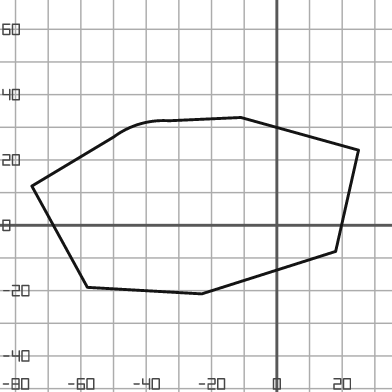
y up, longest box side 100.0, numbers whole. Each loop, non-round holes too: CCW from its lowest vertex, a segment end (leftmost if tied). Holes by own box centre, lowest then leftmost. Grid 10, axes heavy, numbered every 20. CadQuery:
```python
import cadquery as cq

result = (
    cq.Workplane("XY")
    .moveTo(-23.0, -21.0)
    .lineTo(18.0, -8.0)
    .lineTo(25.0, 23.0)
    .lineTo(-11.0, 33.0)
    .lineTo(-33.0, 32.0)
    .threePointArc((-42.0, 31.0), (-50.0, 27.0))
    .lineTo(-75.0, 12.0)
    .lineTo(-58.0, -19.0)
    .close()
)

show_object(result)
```